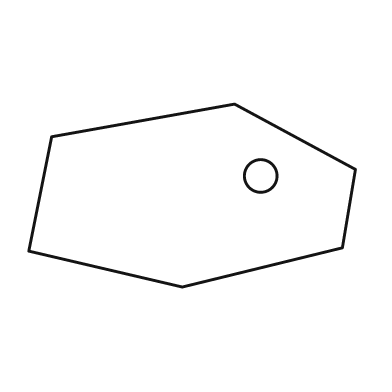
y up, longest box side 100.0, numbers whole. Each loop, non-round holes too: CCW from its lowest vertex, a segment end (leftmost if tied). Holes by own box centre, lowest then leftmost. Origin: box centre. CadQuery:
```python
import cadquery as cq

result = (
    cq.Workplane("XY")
    .moveTo(-3.0, -28.0)
    .lineTo(46.0, -16.0)
    .lineTo(50.0, 8.0)
    .lineTo(13.0, 28.0)
    .lineTo(-43.0, 18.0)
    .lineTo(-50.0, -17.0)
    .close()
    .moveTo(21.0, 6.0)
    .circle(5.0)
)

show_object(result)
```